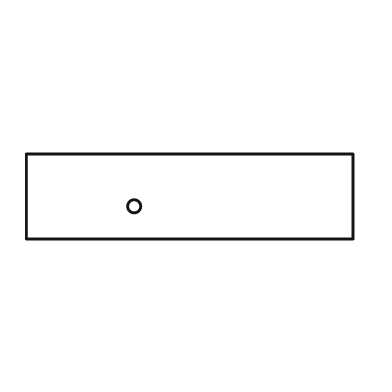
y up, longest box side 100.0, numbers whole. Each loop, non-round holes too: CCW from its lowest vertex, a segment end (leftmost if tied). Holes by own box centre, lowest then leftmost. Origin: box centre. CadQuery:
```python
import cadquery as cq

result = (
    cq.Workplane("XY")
    .moveTo(-50.0, -13.0)
    .lineTo(50.0, -13.0)
    .lineTo(50.0, 13.0)
    .lineTo(-50.0, 13.0)
    .close()
    .moveTo(-17.0, -3.0)
    .circle(2.0)
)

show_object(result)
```